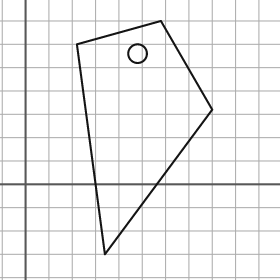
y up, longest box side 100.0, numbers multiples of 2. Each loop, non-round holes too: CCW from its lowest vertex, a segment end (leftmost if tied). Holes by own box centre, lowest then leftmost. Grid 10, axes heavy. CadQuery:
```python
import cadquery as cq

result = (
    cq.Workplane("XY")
    .moveTo(34.0, -30.0)
    .lineTo(80.0, 32.0)
    .lineTo(58.0, 70.0)
    .lineTo(22.0, 60.0)
    .close()
    .moveTo(48.0, 56.0)
    .circle(4.0)
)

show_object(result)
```